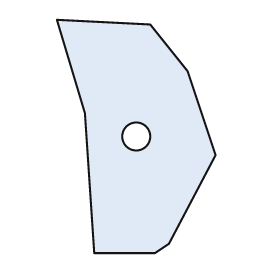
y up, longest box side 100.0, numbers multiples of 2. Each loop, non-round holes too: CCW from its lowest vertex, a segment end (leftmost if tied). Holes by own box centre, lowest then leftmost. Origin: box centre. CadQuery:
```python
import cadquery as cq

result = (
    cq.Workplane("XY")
    .moveTo(-18.0, -50.0)
    .lineTo(8.0, -50.0)
    .lineTo(14.0, -46.0)
    .lineTo(34.0, -8.0)
    .lineTo(22.0, 28.0)
    .lineTo(6.0, 48.0)
    .lineTo(-34.0, 50.0)
    .lineTo(-22.0, 10.0)
    .close()
    .moveTo(0.0, 0.0)
    .circle(6.0)
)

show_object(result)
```